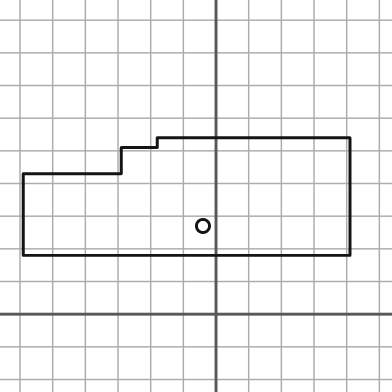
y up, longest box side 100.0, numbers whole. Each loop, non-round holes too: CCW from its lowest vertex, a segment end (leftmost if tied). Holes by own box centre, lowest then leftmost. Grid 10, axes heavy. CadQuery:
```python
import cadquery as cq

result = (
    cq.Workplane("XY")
    .moveTo(-59.0, 18.0)
    .lineTo(41.0, 18.0)
    .lineTo(41.0, 54.0)
    .lineTo(-18.0, 54.0)
    .lineTo(-18.0, 51.0)
    .lineTo(-29.0, 51.0)
    .lineTo(-29.0, 43.0)
    .lineTo(-59.0, 43.0)
    .close()
    .moveTo(-4.0, 27.0)
    .circle(2.0)
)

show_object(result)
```